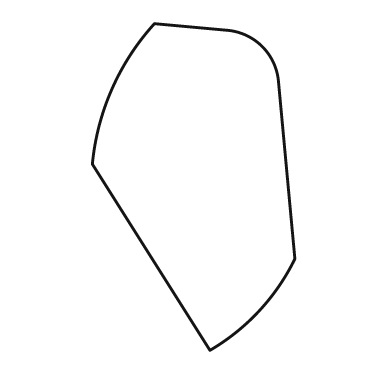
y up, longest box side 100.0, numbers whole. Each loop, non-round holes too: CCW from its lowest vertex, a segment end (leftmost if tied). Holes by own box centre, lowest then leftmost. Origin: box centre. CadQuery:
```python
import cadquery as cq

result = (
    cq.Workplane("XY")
    .moveTo(5.0, -50.0)
    .threePointArc((20.0, -38.0), (31.0, -22.0))
    .lineTo(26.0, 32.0)
    .threePointArc((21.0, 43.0), (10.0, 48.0))
    .lineTo(-12.0, 50.0)
    .threePointArc((-25.0, 30.0), (-31.0, 7.0))
    .close()
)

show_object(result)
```